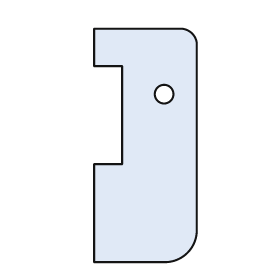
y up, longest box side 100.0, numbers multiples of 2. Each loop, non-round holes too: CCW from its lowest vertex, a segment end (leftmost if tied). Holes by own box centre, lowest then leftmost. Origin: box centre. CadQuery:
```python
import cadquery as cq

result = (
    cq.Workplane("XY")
    .moveTo(-22.0, -50.0)
    .lineTo(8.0, -50.0)
    .threePointArc((18.0, -46.0), (22.0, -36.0))
    .lineTo(22.0, 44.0)
    .threePointArc((20.0, 48.0), (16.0, 50.0))
    .lineTo(-22.0, 50.0)
    .lineTo(-22.0, 34.0)
    .lineTo(-10.0, 34.0)
    .lineTo(-10.0, -8.0)
    .lineTo(-22.0, -8.0)
    .close()
    .moveTo(8.0, 22.0)
    .circle(4.0)
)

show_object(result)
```